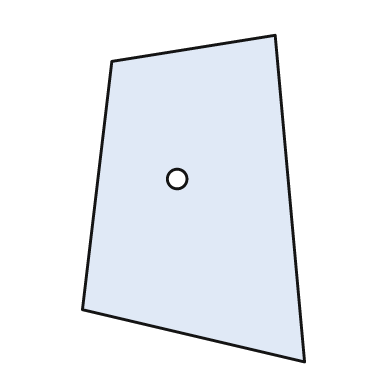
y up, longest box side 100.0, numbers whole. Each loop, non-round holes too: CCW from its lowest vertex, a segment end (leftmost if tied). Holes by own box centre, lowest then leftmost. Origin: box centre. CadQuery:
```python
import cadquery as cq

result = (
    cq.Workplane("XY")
    .moveTo(34.0, -50.0)
    .lineTo(25.0, 50.0)
    .lineTo(-25.0, 42.0)
    .lineTo(-34.0, -34.0)
    .close()
    .moveTo(-5.0, 6.0)
    .circle(3.0)
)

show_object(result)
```